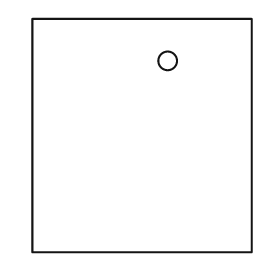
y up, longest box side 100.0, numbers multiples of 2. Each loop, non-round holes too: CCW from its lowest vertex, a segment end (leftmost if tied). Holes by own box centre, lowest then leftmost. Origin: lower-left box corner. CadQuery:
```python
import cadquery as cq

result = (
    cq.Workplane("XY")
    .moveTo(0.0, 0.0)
    .lineTo(94.0, 0.0)
    .lineTo(94.0, 100.0)
    .lineTo(0.0, 100.0)
    .close()
    .moveTo(58.0, 82.0)
    .circle(4.0)
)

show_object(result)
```